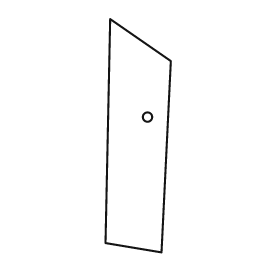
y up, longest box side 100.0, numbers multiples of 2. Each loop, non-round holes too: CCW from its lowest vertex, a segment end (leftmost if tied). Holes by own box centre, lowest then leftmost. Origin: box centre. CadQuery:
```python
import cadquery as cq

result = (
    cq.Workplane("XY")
    .moveTo(10.0, -50.0)
    .lineTo(14.0, 32.0)
    .lineTo(-12.0, 50.0)
    .lineTo(-14.0, -46.0)
    .close()
    .moveTo(4.0, 8.0)
    .circle(2.0)
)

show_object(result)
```